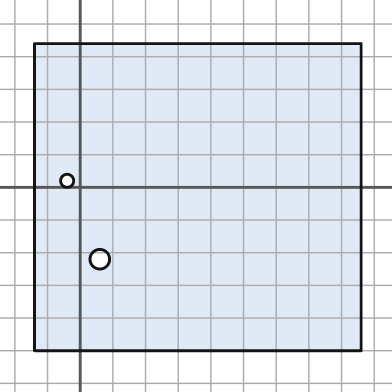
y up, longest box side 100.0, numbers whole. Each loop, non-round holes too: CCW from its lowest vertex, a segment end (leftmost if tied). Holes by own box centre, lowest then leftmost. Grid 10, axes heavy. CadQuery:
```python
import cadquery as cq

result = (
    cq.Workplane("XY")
    .moveTo(-14.0, -50.0)
    .lineTo(86.0, -50.0)
    .lineTo(86.0, 44.0)
    .lineTo(-14.0, 44.0)
    .close()
    .moveTo(6.0, -22.0)
    .circle(3.0)
    .moveTo(-4.0, 2.0)
    .circle(2.0)
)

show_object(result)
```